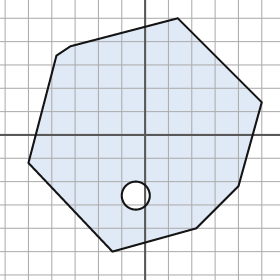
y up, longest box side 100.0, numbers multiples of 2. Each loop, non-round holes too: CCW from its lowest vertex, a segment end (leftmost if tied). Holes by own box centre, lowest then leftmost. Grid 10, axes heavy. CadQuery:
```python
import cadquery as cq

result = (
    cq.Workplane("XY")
    .moveTo(-14.0, -50.0)
    .lineTo(22.0, -40.0)
    .lineTo(40.0, -22.0)
    .lineTo(50.0, 14.0)
    .lineTo(14.0, 50.0)
    .lineTo(-32.0, 38.0)
    .lineTo(-38.0, 34.0)
    .lineTo(-50.0, -12.0)
    .close()
    .moveTo(-4.0, -26.0)
    .circle(6.0)
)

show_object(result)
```